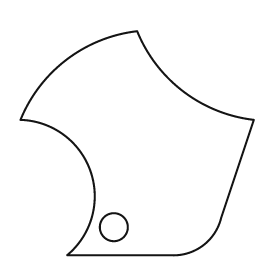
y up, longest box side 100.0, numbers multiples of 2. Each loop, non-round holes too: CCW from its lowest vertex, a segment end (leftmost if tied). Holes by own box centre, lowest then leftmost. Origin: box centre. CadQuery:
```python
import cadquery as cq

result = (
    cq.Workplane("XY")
    .moveTo(-30.0, -48.0)
    .lineTo(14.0, -48.0)
    .threePointArc((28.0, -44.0), (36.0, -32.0))
    .lineTo(50.0, 10.0)
    .threePointArc((20.0, 22.0), (0.0, 48.0))
    .threePointArc((-30.0, 36.0), (-50.0, 10.0))
    .threePointArc((-20.0, -12.0), (-30.0, -48.0))
    .close()
    .moveTo(-10.0, -36.0)
    .circle(6.0)
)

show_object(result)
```